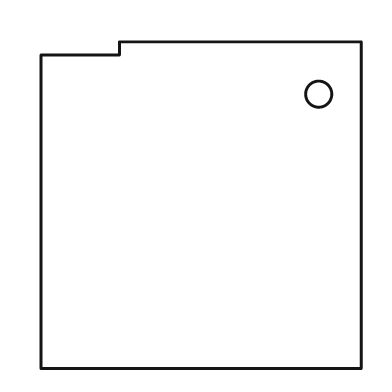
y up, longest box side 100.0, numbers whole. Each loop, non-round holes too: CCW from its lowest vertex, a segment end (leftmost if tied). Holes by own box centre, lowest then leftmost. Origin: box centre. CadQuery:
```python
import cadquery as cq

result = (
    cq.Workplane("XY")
    .moveTo(-49.0, -50.0)
    .lineTo(49.0, -50.0)
    .lineTo(49.0, 50.0)
    .lineTo(-25.0, 50.0)
    .lineTo(-25.0, 46.0)
    .lineTo(-49.0, 46.0)
    .close()
    .moveTo(36.0, 34.0)
    .circle(4.0)
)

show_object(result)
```